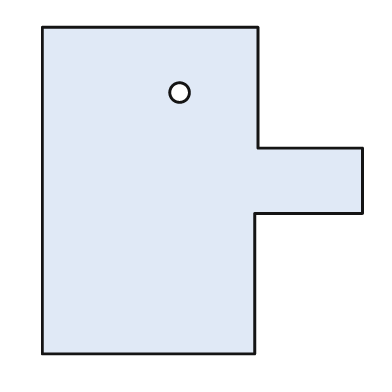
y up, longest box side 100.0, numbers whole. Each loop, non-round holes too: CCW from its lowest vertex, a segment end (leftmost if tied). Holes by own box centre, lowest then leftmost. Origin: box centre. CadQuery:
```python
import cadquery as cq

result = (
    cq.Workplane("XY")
    .moveTo(-49.0, -50.0)
    .lineTo(16.0, -50.0)
    .lineTo(16.0, -7.0)
    .lineTo(49.0, -7.0)
    .lineTo(49.0, 13.0)
    .lineTo(17.0, 13.0)
    .lineTo(17.0, 50.0)
    .lineTo(-49.0, 50.0)
    .close()
    .moveTo(-7.0, 30.0)
    .circle(3.0)
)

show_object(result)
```